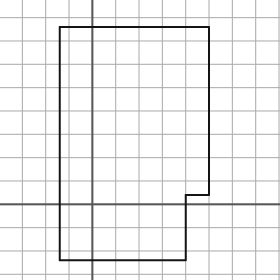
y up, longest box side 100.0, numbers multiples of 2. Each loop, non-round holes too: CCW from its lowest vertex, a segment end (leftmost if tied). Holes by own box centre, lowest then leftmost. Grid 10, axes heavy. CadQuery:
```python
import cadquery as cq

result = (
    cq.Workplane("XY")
    .moveTo(-14.0, -24.0)
    .lineTo(40.0, -24.0)
    .lineTo(40.0, 4.0)
    .lineTo(50.0, 4.0)
    .lineTo(50.0, 76.0)
    .lineTo(-14.0, 76.0)
    .close()
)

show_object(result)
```